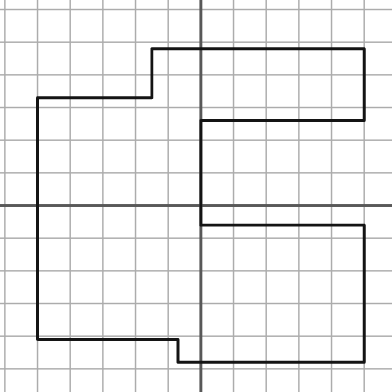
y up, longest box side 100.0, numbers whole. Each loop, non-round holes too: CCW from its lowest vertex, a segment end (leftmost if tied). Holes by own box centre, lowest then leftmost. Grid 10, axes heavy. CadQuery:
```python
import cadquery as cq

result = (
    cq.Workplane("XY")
    .moveTo(-7.0, -48.0)
    .lineTo(50.0, -48.0)
    .lineTo(50.0, -6.0)
    .lineTo(0.0, -6.0)
    .lineTo(0.0, 26.0)
    .lineTo(50.0, 26.0)
    .lineTo(50.0, 48.0)
    .lineTo(-15.0, 48.0)
    .lineTo(-15.0, 33.0)
    .lineTo(-50.0, 33.0)
    .lineTo(-50.0, -41.0)
    .lineTo(-7.0, -41.0)
    .close()
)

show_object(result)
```